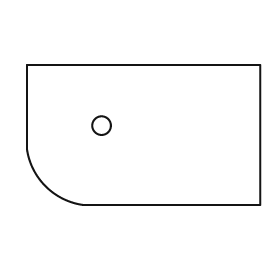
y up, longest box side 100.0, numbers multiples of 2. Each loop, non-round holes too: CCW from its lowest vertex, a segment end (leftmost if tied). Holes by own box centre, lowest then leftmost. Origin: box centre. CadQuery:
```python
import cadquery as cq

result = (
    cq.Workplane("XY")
    .moveTo(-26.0, -30.0)
    .lineTo(50.0, -30.0)
    .lineTo(50.0, 30.0)
    .lineTo(-50.0, 30.0)
    .lineTo(-50.0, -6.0)
    .threePointArc((-42.0, -22.0), (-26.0, -30.0))
    .close()
    .moveTo(-18.0, 4.0)
    .circle(4.0)
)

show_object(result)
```